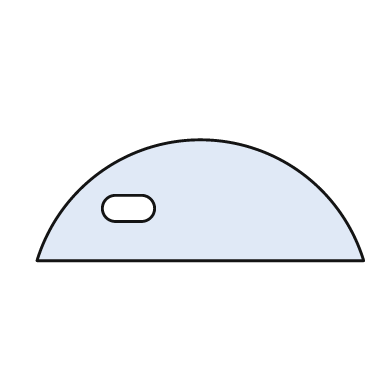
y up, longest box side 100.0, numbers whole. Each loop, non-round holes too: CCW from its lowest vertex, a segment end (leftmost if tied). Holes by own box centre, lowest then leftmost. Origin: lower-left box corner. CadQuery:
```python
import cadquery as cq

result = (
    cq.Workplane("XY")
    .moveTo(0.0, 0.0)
    .lineTo(100.0, 0.0)
    .threePointArc((50.0, 37.0), (0.0, 0.0))
    .close()
    .moveTo(24.0, 12.0)
    .lineTo(32.0, 12.0)
    .threePointArc((36.0, 16.0), (32.0, 20.0))
    .lineTo(24.0, 20.0)
    .threePointArc((20.0, 16.0), (24.0, 12.0))
    .close()
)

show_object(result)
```